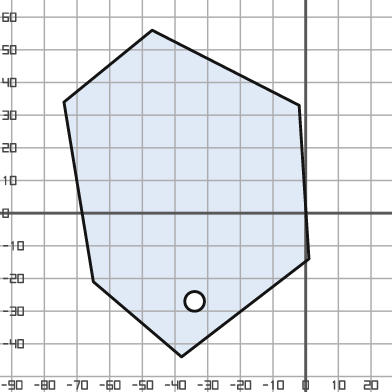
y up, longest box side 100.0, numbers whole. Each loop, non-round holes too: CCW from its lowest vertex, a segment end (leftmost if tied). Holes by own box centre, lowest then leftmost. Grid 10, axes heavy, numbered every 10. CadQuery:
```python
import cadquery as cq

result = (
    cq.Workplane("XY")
    .moveTo(-38.0, -44.0)
    .lineTo(1.0, -14.0)
    .lineTo(-2.0, 33.0)
    .lineTo(-47.0, 56.0)
    .lineTo(-74.0, 34.0)
    .lineTo(-65.0, -21.0)
    .close()
    .moveTo(-34.0, -27.0)
    .circle(3.0)
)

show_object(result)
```